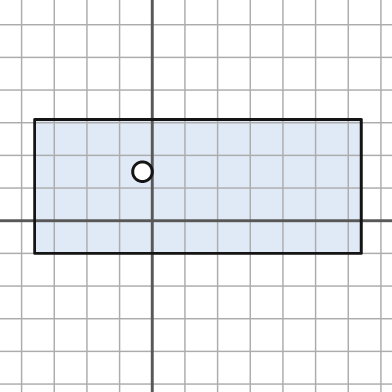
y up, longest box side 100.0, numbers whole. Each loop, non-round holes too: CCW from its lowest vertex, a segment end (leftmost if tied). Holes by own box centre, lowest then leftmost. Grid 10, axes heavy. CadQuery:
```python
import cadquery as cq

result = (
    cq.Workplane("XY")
    .moveTo(-36.0, -10.0)
    .lineTo(64.0, -10.0)
    .lineTo(64.0, 31.0)
    .lineTo(-36.0, 31.0)
    .close()
    .moveTo(-3.0, 15.0)
    .circle(3.0)
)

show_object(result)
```